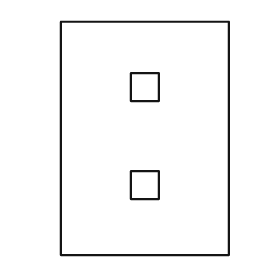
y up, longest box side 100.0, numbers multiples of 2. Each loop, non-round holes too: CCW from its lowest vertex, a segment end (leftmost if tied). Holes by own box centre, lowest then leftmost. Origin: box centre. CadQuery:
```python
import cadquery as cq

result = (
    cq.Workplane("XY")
    .moveTo(-36.0, -50.0)
    .lineTo(36.0, -50.0)
    .lineTo(36.0, 50.0)
    .lineTo(-36.0, 50.0)
    .close()
    .moveTo(-6.0, -26.0)
    .lineTo(6.0, -26.0)
    .lineTo(6.0, -14.0)
    .lineTo(-6.0, -14.0)
    .close()
    .moveTo(-6.0, 16.0)
    .lineTo(6.0, 16.0)
    .lineTo(6.0, 28.0)
    .lineTo(-6.0, 28.0)
    .close()
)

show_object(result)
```